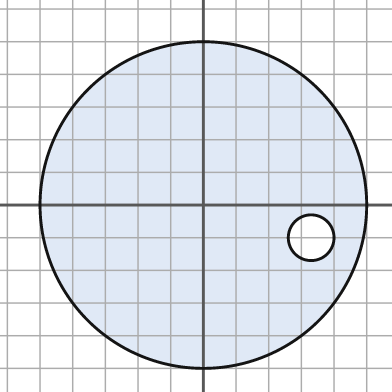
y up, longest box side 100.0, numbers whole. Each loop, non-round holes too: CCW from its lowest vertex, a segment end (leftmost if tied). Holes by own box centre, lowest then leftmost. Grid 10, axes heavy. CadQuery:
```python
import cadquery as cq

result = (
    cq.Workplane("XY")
    .moveTo(0.0, 0.0)
    .circle(50.0)
    .moveTo(33.0, -10.0)
    .circle(7.0)
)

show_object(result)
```